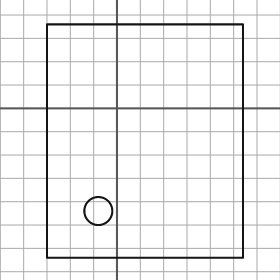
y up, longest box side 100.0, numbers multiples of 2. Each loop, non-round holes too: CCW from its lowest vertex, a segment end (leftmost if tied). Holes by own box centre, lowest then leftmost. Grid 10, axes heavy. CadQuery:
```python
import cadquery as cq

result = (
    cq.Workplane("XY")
    .moveTo(-30.0, -64.0)
    .lineTo(54.0, -64.0)
    .lineTo(54.0, 36.0)
    .lineTo(-30.0, 36.0)
    .close()
    .moveTo(-8.0, -44.0)
    .circle(6.0)
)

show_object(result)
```